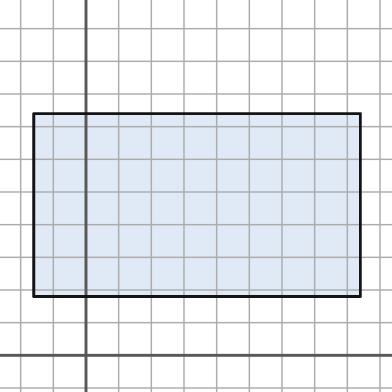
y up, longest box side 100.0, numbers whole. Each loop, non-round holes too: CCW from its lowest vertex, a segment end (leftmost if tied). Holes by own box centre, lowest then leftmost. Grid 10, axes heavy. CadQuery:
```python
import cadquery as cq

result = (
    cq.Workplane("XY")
    .moveTo(-16.0, 18.0)
    .lineTo(84.0, 18.0)
    .lineTo(84.0, 74.0)
    .lineTo(-16.0, 74.0)
    .close()
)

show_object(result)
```